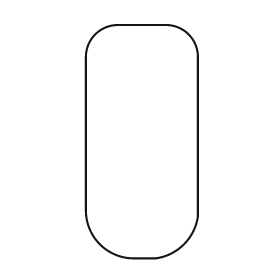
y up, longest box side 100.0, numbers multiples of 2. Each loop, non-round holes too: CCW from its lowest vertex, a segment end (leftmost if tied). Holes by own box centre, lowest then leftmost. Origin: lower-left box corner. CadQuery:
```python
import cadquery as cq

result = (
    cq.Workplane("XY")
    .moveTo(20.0, 0.0)
    .lineTo(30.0, 0.0)
    .threePointArc((42.0, 6.0), (48.0, 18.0))
    .lineTo(48.0, 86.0)
    .threePointArc((44.0, 96.0), (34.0, 100.0))
    .lineTo(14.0, 100.0)
    .threePointArc((4.0, 96.0), (0.0, 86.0))
    .lineTo(0.0, 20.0)
    .threePointArc((6.0, 6.0), (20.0, 0.0))
    .close()
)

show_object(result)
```